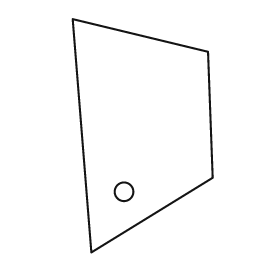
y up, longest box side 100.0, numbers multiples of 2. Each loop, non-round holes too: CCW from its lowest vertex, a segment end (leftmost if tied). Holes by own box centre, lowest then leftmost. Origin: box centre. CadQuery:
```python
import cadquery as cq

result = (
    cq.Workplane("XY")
    .moveTo(-22.0, -50.0)
    .lineTo(30.0, -18.0)
    .lineTo(28.0, 36.0)
    .lineTo(-30.0, 50.0)
    .close()
    .moveTo(-8.0, -24.0)
    .circle(4.0)
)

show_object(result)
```